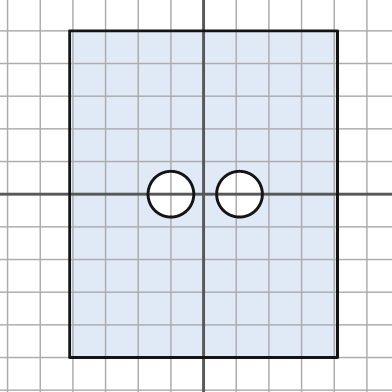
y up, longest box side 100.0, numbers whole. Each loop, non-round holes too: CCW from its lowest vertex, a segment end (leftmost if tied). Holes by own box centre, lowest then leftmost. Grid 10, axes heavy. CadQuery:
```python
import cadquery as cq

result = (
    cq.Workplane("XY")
    .moveTo(-41.0, -50.0)
    .lineTo(41.0, -50.0)
    .lineTo(41.0, 50.0)
    .lineTo(-41.0, 50.0)
    .close()
    .moveTo(-10.0, 0.0)
    .circle(7.0)
    .moveTo(11.0, 0.0)
    .circle(7.0)
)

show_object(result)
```